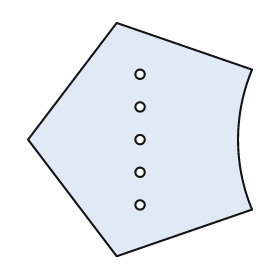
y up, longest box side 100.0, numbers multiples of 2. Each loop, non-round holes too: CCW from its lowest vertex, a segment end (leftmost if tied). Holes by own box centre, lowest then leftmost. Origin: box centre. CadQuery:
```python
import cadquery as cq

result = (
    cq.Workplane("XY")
    .moveTo(-10.0, -50.0)
    .lineTo(48.0, -30.0)
    .threePointArc((42.0, 0.0), (48.0, 30.0))
    .lineTo(-10.0, 50.0)
    .lineTo(-48.0, 0.0)
    .close()
    .moveTo(0.0, -28.0)
    .circle(2.0)
    .moveTo(0.0, -14.0)
    .circle(2.0)
    .moveTo(0.0, 0.0)
    .circle(2.0)
    .moveTo(0.0, 14.0)
    .circle(2.0)
    .moveTo(0.0, 28.0)
    .circle(2.0)
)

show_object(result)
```